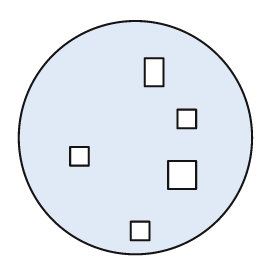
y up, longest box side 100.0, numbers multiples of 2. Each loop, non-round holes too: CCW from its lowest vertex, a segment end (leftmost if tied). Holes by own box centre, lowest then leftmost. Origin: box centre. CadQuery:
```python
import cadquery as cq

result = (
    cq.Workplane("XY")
    .moveTo(0.0, 0.0)
    .circle(50.0)
    .moveTo(-2.0, -44.0)
    .lineTo(6.0, -44.0)
    .lineTo(6.0, -36.0)
    .lineTo(-2.0, -36.0)
    .close()
    .moveTo(14.0, -22.0)
    .lineTo(26.0, -22.0)
    .lineTo(26.0, -10.0)
    .lineTo(14.0, -10.0)
    .close()
    .moveTo(-28.0, -12.0)
    .lineTo(-20.0, -12.0)
    .lineTo(-20.0, -4.0)
    .lineTo(-28.0, -4.0)
    .close()
    .moveTo(18.0, 4.0)
    .lineTo(26.0, 4.0)
    .lineTo(26.0, 12.0)
    .lineTo(18.0, 12.0)
    .close()
    .moveTo(4.0, 22.0)
    .lineTo(12.0, 22.0)
    .lineTo(12.0, 34.0)
    .lineTo(4.0, 34.0)
    .close()
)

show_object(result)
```